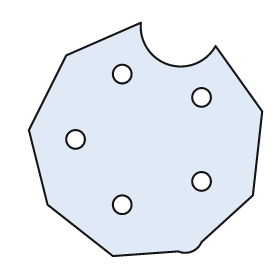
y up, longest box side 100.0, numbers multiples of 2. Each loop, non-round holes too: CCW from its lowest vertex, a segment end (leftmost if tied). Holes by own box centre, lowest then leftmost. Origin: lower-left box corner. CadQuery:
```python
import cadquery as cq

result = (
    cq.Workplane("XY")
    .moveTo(36.0, 0.0)
    .lineTo(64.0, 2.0)
    .threePointArc((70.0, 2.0), (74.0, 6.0))
    .lineTo(96.0, 26.0)
    .lineTo(100.0, 62.0)
    .lineTo(80.0, 90.0)
    .threePointArc((60.0, 82.0), (48.0, 100.0))
    .lineTo(16.0, 86.0)
    .lineTo(0.0, 54.0)
    .lineTo(8.0, 22.0)
    .close()
    .moveTo(40.0, 22.0)
    .circle(4.0)
    .moveTo(74.0, 32.0)
    .circle(4.0)
    .moveTo(20.0, 50.0)
    .circle(4.0)
    .moveTo(74.0, 68.0)
    .circle(4.0)
    .moveTo(40.0, 78.0)
    .circle(4.0)
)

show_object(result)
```